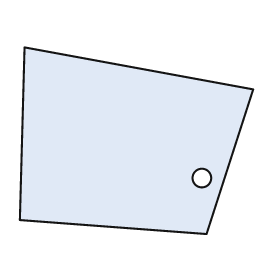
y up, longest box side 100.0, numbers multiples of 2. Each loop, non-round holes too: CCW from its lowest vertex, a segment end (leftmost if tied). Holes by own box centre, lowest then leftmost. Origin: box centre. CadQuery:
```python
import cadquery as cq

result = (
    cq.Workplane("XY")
    .moveTo(30.0, -40.0)
    .lineTo(50.0, 22.0)
    .lineTo(-48.0, 40.0)
    .lineTo(-50.0, -34.0)
    .close()
    .moveTo(28.0, -16.0)
    .circle(4.0)
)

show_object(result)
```